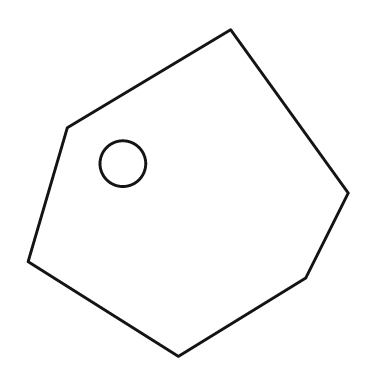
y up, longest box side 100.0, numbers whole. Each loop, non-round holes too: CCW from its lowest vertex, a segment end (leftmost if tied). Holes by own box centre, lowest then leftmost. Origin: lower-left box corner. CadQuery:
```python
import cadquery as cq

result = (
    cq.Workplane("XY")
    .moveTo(46.0, 0.0)
    .lineTo(85.0, 24.0)
    .lineTo(98.0, 50.0)
    .lineTo(62.0, 100.0)
    .lineTo(12.0, 70.0)
    .lineTo(0.0, 29.0)
    .close()
    .moveTo(29.0, 59.0)
    .circle(7.0)
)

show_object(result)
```